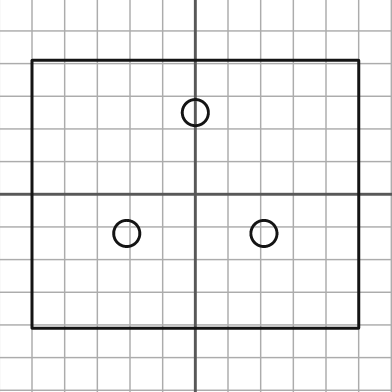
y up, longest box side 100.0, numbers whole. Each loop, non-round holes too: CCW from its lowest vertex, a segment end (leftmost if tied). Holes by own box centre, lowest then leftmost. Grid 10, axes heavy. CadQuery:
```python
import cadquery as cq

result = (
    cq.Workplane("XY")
    .moveTo(-50.0, -41.0)
    .lineTo(50.0, -41.0)
    .lineTo(50.0, 41.0)
    .lineTo(-50.0, 41.0)
    .close()
    .moveTo(-21.0, -12.0)
    .circle(4.0)
    .moveTo(21.0, -12.0)
    .circle(4.0)
    .moveTo(0.0, 25.0)
    .circle(4.0)
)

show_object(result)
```